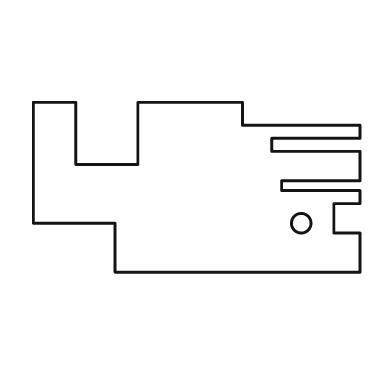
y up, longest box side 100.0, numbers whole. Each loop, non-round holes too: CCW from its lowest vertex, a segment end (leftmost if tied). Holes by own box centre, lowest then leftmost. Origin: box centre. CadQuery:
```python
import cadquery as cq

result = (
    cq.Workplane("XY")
    .moveTo(-25.0, -26.0)
    .lineTo(50.0, -26.0)
    .lineTo(50.0, -14.0)
    .lineTo(42.0, -14.0)
    .lineTo(42.0, -5.0)
    .lineTo(50.0, -5.0)
    .lineTo(50.0, -1.0)
    .lineTo(26.0, -1.0)
    .lineTo(26.0, 2.0)
    .lineTo(50.0, 2.0)
    .lineTo(50.0, 11.0)
    .lineTo(23.0, 11.0)
    .lineTo(23.0, 15.0)
    .lineTo(50.0, 15.0)
    .lineTo(50.0, 19.0)
    .lineTo(14.0, 19.0)
    .lineTo(14.0, 26.0)
    .lineTo(-18.0, 26.0)
    .lineTo(-18.0, 7.0)
    .lineTo(-37.0, 7.0)
    .lineTo(-37.0, 26.0)
    .lineTo(-50.0, 26.0)
    .lineTo(-50.0, -11.0)
    .lineTo(-25.0, -11.0)
    .close()
    .moveTo(32.0, -11.0)
    .circle(3.0)
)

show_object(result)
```